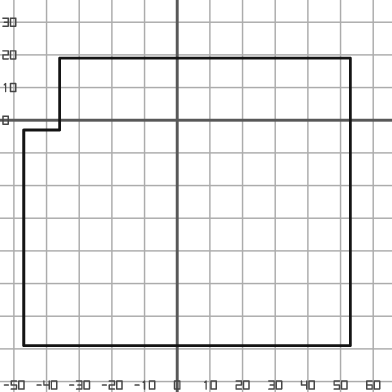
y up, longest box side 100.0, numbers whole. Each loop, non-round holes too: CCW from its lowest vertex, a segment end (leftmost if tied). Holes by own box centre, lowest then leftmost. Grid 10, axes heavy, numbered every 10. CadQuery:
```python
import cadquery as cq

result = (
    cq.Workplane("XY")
    .moveTo(-47.0, -69.0)
    .lineTo(53.0, -69.0)
    .lineTo(53.0, 19.0)
    .lineTo(-36.0, 19.0)
    .lineTo(-36.0, -3.0)
    .lineTo(-47.0, -3.0)
    .close()
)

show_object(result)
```